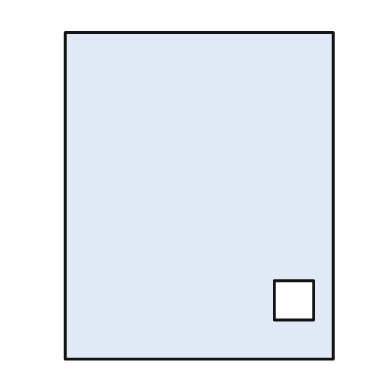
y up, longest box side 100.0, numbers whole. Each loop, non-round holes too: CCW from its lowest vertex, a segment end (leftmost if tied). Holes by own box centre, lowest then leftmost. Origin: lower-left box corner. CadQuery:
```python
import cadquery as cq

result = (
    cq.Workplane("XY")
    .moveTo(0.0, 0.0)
    .lineTo(82.0, 0.0)
    .lineTo(82.0, 100.0)
    .lineTo(0.0, 100.0)
    .close()
    .moveTo(64.0, 12.0)
    .lineTo(76.0, 12.0)
    .lineTo(76.0, 24.0)
    .lineTo(64.0, 24.0)
    .close()
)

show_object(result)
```